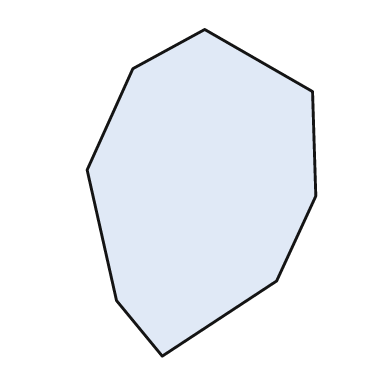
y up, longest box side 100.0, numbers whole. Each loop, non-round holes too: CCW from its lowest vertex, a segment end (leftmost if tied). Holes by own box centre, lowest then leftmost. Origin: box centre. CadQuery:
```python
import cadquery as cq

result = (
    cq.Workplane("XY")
    .moveTo(-12.0, -50.0)
    .lineTo(23.0, -27.0)
    .lineTo(35.0, -1.0)
    .lineTo(34.0, 31.0)
    .lineTo(1.0, 50.0)
    .lineTo(-21.0, 38.0)
    .lineTo(-35.0, 7.0)
    .lineTo(-26.0, -33.0)
    .close()
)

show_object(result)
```